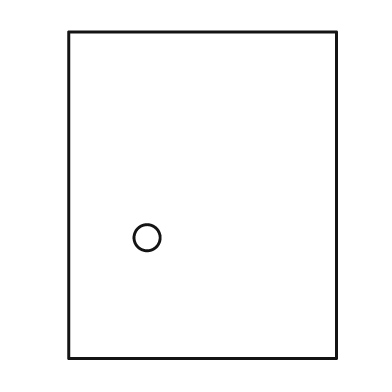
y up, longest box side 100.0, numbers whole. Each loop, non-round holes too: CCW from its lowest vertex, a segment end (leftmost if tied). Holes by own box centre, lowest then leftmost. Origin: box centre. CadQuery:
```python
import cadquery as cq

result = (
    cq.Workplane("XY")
    .moveTo(-41.0, -50.0)
    .lineTo(41.0, -50.0)
    .lineTo(41.0, 50.0)
    .lineTo(-41.0, 50.0)
    .close()
    .moveTo(-17.0, -13.0)
    .circle(4.0)
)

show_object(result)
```